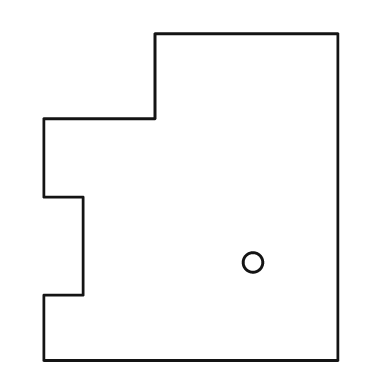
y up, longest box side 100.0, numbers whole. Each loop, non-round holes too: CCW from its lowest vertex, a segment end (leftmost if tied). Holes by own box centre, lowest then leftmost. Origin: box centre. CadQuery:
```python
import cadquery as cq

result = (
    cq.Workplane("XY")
    .moveTo(-45.0, -50.0)
    .lineTo(45.0, -50.0)
    .lineTo(45.0, 50.0)
    .lineTo(-11.0, 50.0)
    .lineTo(-11.0, 24.0)
    .lineTo(-45.0, 24.0)
    .lineTo(-45.0, 0.0)
    .lineTo(-33.0, 0.0)
    .lineTo(-33.0, -30.0)
    .lineTo(-45.0, -30.0)
    .close()
    .moveTo(19.0, -20.0)
    .circle(3.0)
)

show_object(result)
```